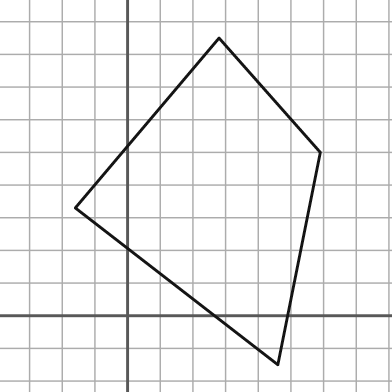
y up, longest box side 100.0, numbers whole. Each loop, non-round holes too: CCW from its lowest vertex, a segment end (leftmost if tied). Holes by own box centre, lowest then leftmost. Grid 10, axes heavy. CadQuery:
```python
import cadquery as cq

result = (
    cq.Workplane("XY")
    .moveTo(46.0, -15.0)
    .lineTo(59.0, 50.0)
    .lineTo(28.0, 85.0)
    .lineTo(-16.0, 33.0)
    .close()
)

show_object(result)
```